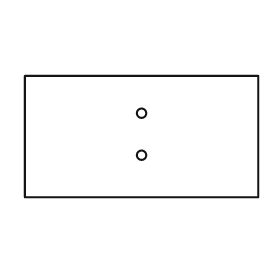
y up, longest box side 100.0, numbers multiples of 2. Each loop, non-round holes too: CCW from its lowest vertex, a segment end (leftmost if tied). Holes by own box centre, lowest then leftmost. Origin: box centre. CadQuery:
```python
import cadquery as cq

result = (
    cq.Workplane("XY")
    .moveTo(-50.0, -26.0)
    .lineTo(50.0, -26.0)
    .lineTo(50.0, 26.0)
    .lineTo(-50.0, 26.0)
    .close()
    .moveTo(0.0, -8.0)
    .circle(2.0)
    .moveTo(0.0, 10.0)
    .circle(2.0)
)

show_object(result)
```